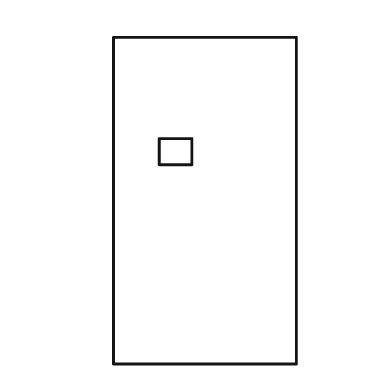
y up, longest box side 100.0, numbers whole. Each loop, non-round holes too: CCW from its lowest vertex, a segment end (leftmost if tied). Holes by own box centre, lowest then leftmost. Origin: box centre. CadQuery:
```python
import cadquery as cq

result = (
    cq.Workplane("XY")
    .moveTo(-28.0, -50.0)
    .lineTo(28.0, -50.0)
    .lineTo(28.0, 50.0)
    .lineTo(-28.0, 50.0)
    .close()
    .moveTo(-14.0, 11.0)
    .lineTo(-4.0, 11.0)
    .lineTo(-4.0, 19.0)
    .lineTo(-14.0, 19.0)
    .close()
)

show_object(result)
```